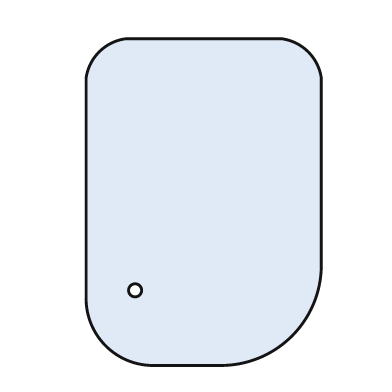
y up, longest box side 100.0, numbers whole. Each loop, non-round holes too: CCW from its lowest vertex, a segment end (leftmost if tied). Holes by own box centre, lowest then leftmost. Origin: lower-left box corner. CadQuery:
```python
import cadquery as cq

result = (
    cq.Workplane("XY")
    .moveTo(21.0, 0.0)
    .lineTo(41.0, 0.0)
    .threePointArc((63.0, 9.0), (72.0, 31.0))
    .lineTo(72.0, 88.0)
    .threePointArc((68.0, 96.0), (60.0, 100.0))
    .lineTo(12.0, 100.0)
    .threePointArc((4.0, 96.0), (0.0, 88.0))
    .lineTo(0.0, 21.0)
    .threePointArc((6.0, 6.0), (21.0, 0.0))
    .close()
    .moveTo(15.0, 23.0)
    .circle(2.0)
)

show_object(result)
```